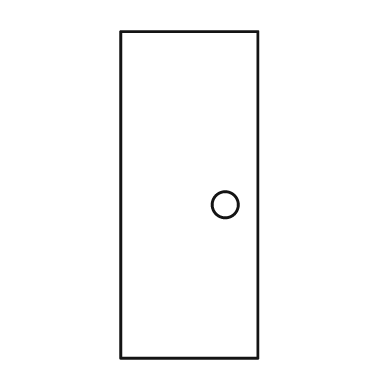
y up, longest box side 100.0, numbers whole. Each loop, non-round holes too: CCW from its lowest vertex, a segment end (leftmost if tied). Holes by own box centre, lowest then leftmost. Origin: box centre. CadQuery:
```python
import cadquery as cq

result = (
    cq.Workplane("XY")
    .moveTo(-21.0, -50.0)
    .lineTo(21.0, -50.0)
    .lineTo(21.0, 50.0)
    .lineTo(-21.0, 50.0)
    .close()
    .moveTo(11.0, -3.0)
    .circle(4.0)
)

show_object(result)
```